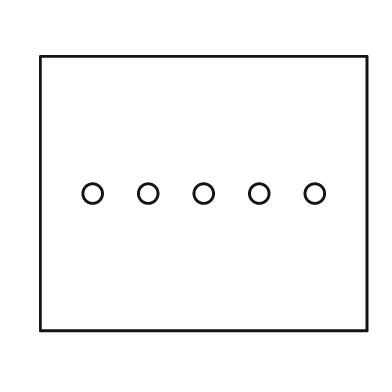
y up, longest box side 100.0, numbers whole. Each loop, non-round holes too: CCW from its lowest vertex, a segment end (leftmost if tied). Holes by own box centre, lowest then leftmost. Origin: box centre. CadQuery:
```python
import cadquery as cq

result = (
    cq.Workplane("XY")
    .moveTo(-50.0, -42.0)
    .lineTo(50.0, -42.0)
    .lineTo(50.0, 42.0)
    .lineTo(-50.0, 42.0)
    .close()
    .moveTo(-34.0, 0.0)
    .circle(3.0)
    .moveTo(-17.0, 0.0)
    .circle(3.0)
    .moveTo(0.0, 0.0)
    .circle(3.0)
    .moveTo(17.0, 0.0)
    .circle(3.0)
    .moveTo(34.0, 0.0)
    .circle(3.0)
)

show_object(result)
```